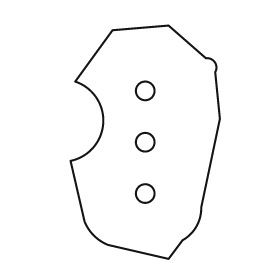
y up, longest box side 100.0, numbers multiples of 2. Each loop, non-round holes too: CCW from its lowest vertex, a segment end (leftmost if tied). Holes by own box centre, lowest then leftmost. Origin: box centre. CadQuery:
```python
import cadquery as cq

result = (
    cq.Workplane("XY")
    .moveTo(10.0, -50.0)
    .lineTo(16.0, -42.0)
    .threePointArc((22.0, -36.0), (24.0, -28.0))
    .lineTo(32.0, 10.0)
    .lineTo(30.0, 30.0)
    .threePointArc((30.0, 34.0), (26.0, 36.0))
    .lineTo(10.0, 50.0)
    .lineTo(-14.0, 48.0)
    .lineTo(-30.0, 26.0)
    .threePointArc((-18.0, 8.0), (-32.0, -8.0))
    .lineTo(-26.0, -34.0)
    .threePointArc((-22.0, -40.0), (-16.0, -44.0))
    .close()
    .moveTo(0.0, -22.0)
    .circle(4.0)
    .moveTo(0.0, 0.0)
    .circle(4.0)
    .moveTo(0.0, 22.0)
    .circle(4.0)
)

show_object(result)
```